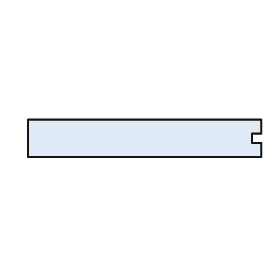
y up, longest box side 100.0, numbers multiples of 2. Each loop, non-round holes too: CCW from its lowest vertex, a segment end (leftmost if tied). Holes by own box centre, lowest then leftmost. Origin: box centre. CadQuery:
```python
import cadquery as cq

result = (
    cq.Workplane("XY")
    .moveTo(-50.0, -8.0)
    .lineTo(50.0, -8.0)
    .lineTo(50.0, -2.0)
    .lineTo(46.0, -2.0)
    .lineTo(46.0, 2.0)
    .lineTo(50.0, 2.0)
    .lineTo(50.0, 8.0)
    .lineTo(-50.0, 8.0)
    .close()
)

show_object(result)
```